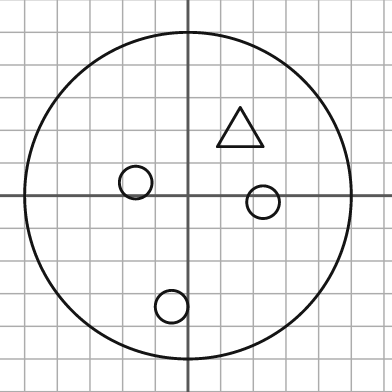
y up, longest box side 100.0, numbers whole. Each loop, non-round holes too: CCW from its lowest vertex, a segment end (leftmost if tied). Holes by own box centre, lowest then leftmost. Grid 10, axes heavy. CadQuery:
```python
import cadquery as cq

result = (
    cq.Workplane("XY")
    .moveTo(0.0, 0.0)
    .circle(50.0)
    .moveTo(-5.0, -34.0)
    .circle(5.0)
    .moveTo(23.0, -2.0)
    .circle(5.0)
    .moveTo(-16.0, 4.0)
    .circle(5.0)
    .moveTo(9.0, 15.0)
    .lineTo(23.0, 15.0)
    .lineTo(16.0, 27.0)
    .close()
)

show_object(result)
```